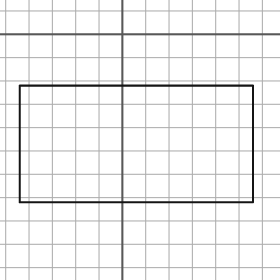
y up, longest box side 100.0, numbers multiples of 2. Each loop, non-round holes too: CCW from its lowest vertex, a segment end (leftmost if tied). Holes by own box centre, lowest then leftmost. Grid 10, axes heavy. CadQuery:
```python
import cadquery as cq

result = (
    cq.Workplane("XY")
    .moveTo(-44.0, -72.0)
    .lineTo(56.0, -72.0)
    .lineTo(56.0, -22.0)
    .lineTo(-44.0, -22.0)
    .close()
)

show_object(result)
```